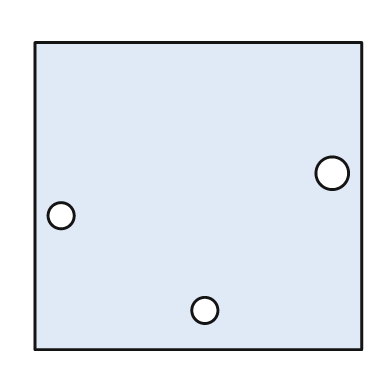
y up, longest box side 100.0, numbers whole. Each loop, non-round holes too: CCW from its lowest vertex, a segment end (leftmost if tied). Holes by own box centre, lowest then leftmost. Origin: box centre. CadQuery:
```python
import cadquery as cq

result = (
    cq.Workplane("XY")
    .moveTo(-50.0, -47.0)
    .lineTo(50.0, -47.0)
    .lineTo(50.0, 47.0)
    .lineTo(-50.0, 47.0)
    .close()
    .moveTo(2.0, -35.0)
    .circle(4.0)
    .moveTo(-42.0, -6.0)
    .circle(4.0)
    .moveTo(41.0, 7.0)
    .circle(5.0)
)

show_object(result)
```